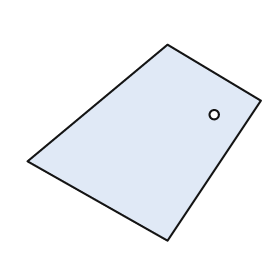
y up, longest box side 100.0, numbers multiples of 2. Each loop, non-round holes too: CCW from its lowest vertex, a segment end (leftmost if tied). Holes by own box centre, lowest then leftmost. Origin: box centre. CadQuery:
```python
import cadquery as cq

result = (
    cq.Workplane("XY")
    .moveTo(10.0, -42.0)
    .lineTo(50.0, 18.0)
    .lineTo(10.0, 42.0)
    .lineTo(-50.0, -8.0)
    .close()
    .moveTo(30.0, 12.0)
    .circle(2.0)
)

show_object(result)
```